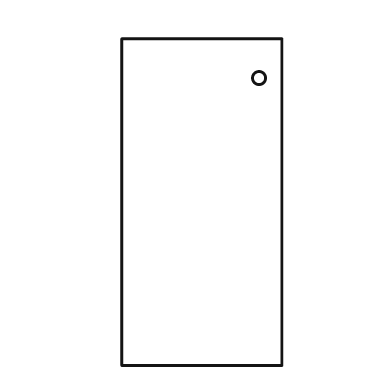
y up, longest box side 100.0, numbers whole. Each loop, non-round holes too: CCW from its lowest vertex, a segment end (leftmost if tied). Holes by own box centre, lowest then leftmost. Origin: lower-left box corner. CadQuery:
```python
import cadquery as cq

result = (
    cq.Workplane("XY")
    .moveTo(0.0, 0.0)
    .lineTo(49.0, 0.0)
    .lineTo(49.0, 100.0)
    .lineTo(0.0, 100.0)
    .close()
    .moveTo(42.0, 88.0)
    .circle(2.0)
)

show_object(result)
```